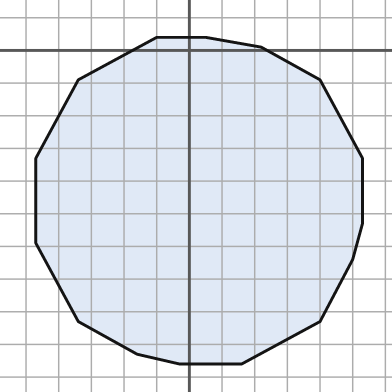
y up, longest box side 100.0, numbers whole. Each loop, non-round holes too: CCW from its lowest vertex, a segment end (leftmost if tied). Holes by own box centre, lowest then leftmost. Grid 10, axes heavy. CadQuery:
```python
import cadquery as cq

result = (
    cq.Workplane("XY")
    .moveTo(-3.0, -96.0)
    .lineTo(16.0, -96.0)
    .lineTo(40.0, -83.0)
    .lineTo(50.0, -64.0)
    .lineTo(53.0, -53.0)
    .lineTo(53.0, -33.0)
    .lineTo(40.0, -9.0)
    .lineTo(22.0, 1.0)
    .lineTo(5.0, 4.0)
    .lineTo(-10.0, 4.0)
    .lineTo(-34.0, -9.0)
    .lineTo(-47.0, -33.0)
    .lineTo(-47.0, -59.0)
    .lineTo(-34.0, -83.0)
    .lineTo(-16.0, -93.0)
    .close()
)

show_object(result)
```